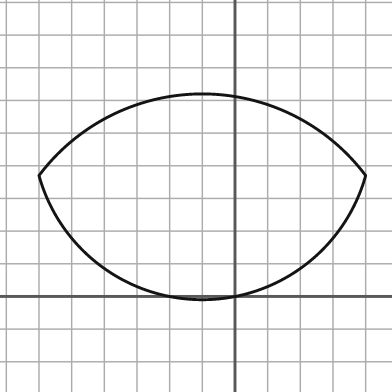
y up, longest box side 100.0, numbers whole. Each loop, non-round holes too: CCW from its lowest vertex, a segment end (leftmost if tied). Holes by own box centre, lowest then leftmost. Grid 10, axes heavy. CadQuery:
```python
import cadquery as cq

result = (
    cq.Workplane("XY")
    .moveTo(-60.0, 37.0)
    .threePointArc((-10.0, -1.0), (40.0, 37.0))
    .threePointArc((-10.0, 62.0), (-60.0, 37.0))
    .close()
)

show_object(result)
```